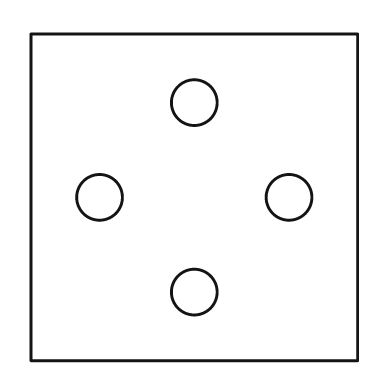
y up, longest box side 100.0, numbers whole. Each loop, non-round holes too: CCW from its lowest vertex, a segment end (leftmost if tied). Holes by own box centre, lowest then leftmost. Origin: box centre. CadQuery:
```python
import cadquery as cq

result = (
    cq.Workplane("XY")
    .moveTo(-50.0, -50.0)
    .lineTo(50.0, -50.0)
    .lineTo(50.0, 50.0)
    .lineTo(-50.0, 50.0)
    .close()
    .moveTo(0.0, -29.0)
    .circle(7.0)
    .moveTo(-29.0, 0.0)
    .circle(7.0)
    .moveTo(29.0, 0.0)
    .circle(7.0)
    .moveTo(0.0, 29.0)
    .circle(7.0)
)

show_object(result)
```